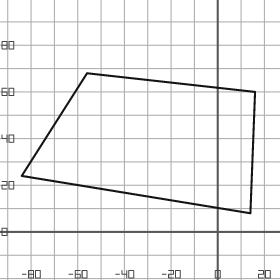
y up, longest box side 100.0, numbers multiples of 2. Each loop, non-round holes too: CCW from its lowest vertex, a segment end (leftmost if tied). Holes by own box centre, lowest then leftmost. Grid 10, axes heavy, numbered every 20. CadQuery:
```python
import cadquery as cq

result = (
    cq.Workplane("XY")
    .moveTo(14.0, 8.0)
    .lineTo(16.0, 60.0)
    .lineTo(-56.0, 68.0)
    .lineTo(-84.0, 24.0)
    .close()
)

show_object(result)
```